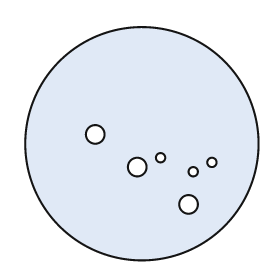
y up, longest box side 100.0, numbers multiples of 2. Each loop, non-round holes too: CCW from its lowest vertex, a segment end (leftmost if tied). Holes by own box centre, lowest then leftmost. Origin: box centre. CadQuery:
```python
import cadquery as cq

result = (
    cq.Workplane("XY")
    .moveTo(0.0, 0.0)
    .circle(50.0)
    .moveTo(20.0, -26.0)
    .circle(4.0)
    .moveTo(22.0, -12.0)
    .circle(2.0)
    .moveTo(-2.0, -10.0)
    .circle(4.0)
    .moveTo(30.0, -8.0)
    .circle(2.0)
    .moveTo(8.0, -6.0)
    .circle(2.0)
    .moveTo(-20.0, 4.0)
    .circle(4.0)
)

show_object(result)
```